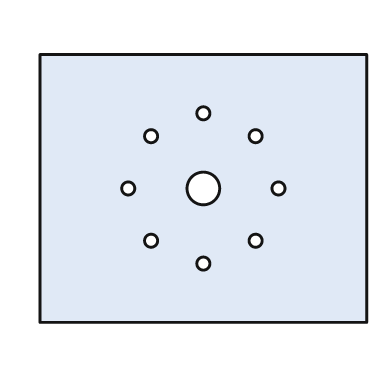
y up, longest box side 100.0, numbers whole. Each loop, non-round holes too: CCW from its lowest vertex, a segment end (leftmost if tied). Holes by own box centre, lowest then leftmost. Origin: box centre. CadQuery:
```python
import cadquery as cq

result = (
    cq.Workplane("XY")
    .moveTo(-50.0, -41.0)
    .lineTo(50.0, -41.0)
    .lineTo(50.0, 41.0)
    .lineTo(-50.0, 41.0)
    .close()
    .moveTo(0.0, -23.0)
    .circle(2.0)
    .moveTo(-16.0, -16.0)
    .circle(2.0)
    .moveTo(16.0, -16.0)
    .circle(2.0)
    .moveTo(-23.0, 0.0)
    .circle(2.0)
    .moveTo(0.0, 0.0)
    .circle(5.0)
    .moveTo(23.0, 0.0)
    .circle(2.0)
    .moveTo(-16.0, 16.0)
    .circle(2.0)
    .moveTo(16.0, 16.0)
    .circle(2.0)
    .moveTo(0.0, 23.0)
    .circle(2.0)
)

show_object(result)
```